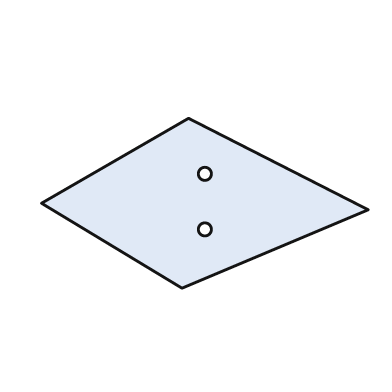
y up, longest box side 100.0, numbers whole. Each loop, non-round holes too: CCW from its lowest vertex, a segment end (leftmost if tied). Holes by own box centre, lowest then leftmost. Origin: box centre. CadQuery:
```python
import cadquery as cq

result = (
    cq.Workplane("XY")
    .moveTo(-7.0, -26.0)
    .lineTo(50.0, -2.0)
    .lineTo(-5.0, 26.0)
    .lineTo(-50.0, 0.0)
    .close()
    .moveTo(0.0, -8.0)
    .circle(2.0)
    .moveTo(0.0, 9.0)
    .circle(2.0)
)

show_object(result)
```